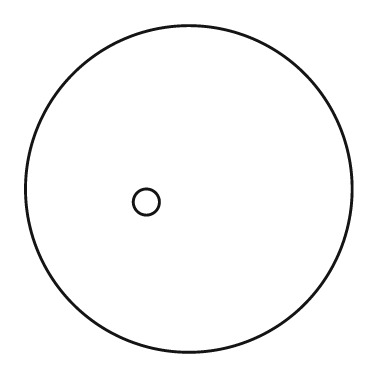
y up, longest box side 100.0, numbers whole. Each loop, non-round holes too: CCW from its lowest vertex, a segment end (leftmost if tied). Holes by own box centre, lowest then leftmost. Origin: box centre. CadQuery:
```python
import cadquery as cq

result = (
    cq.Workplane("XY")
    .moveTo(0.0, 0.0)
    .circle(50.0)
    .moveTo(-13.0, -4.0)
    .circle(4.0)
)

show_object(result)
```